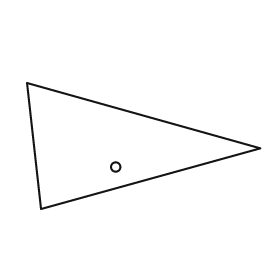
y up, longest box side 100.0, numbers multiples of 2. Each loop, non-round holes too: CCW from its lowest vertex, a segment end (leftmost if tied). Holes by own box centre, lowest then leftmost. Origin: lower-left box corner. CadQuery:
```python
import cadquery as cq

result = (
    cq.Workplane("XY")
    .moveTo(6.0, 0.0)
    .lineTo(100.0, 26.0)
    .lineTo(0.0, 54.0)
    .close()
    .moveTo(38.0, 18.0)
    .circle(2.0)
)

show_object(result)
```